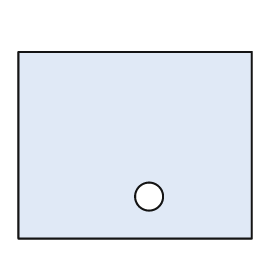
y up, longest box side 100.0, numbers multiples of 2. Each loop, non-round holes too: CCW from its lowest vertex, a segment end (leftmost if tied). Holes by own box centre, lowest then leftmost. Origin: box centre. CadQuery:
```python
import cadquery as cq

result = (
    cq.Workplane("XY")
    .moveTo(-50.0, -40.0)
    .lineTo(50.0, -40.0)
    .lineTo(50.0, 40.0)
    .lineTo(-50.0, 40.0)
    .close()
    .moveTo(6.0, -22.0)
    .circle(6.0)
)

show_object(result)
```